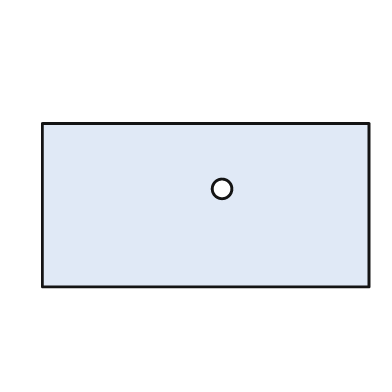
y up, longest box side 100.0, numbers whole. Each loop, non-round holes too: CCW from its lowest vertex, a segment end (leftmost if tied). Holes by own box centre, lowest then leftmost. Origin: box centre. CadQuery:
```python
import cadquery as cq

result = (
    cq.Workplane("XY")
    .moveTo(-50.0, -25.0)
    .lineTo(50.0, -25.0)
    .lineTo(50.0, 25.0)
    .lineTo(-50.0, 25.0)
    .close()
    .moveTo(5.0, 5.0)
    .circle(3.0)
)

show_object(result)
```